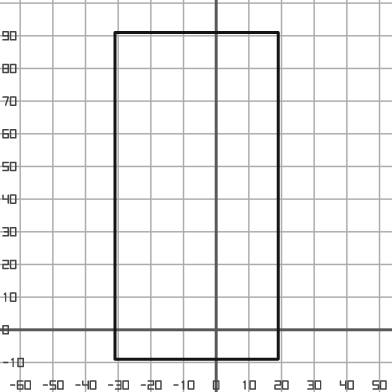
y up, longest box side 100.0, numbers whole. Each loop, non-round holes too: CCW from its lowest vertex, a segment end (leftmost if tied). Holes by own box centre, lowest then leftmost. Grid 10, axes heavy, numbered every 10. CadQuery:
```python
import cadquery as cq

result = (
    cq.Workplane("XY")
    .moveTo(-31.0, -9.0)
    .lineTo(19.0, -9.0)
    .lineTo(19.0, 91.0)
    .lineTo(-31.0, 91.0)
    .close()
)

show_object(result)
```